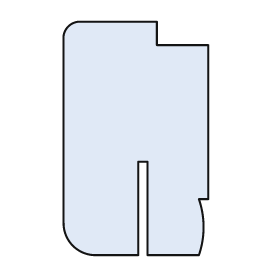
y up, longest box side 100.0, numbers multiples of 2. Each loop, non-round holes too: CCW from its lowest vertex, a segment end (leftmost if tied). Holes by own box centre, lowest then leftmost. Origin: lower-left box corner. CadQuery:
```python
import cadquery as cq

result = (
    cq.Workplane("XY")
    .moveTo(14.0, 0.0)
    .lineTo(32.0, 0.0)
    .lineTo(32.0, 40.0)
    .lineTo(36.0, 40.0)
    .lineTo(36.0, 0.0)
    .lineTo(58.0, 0.0)
    .threePointArc((60.0, 12.0), (58.0, 24.0))
    .lineTo(62.0, 24.0)
    .lineTo(62.0, 90.0)
    .lineTo(40.0, 90.0)
    .lineTo(40.0, 100.0)
    .lineTo(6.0, 100.0)
    .threePointArc((2.0, 98.0), (0.0, 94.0))
    .lineTo(0.0, 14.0)
    .threePointArc((4.0, 4.0), (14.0, 0.0))
    .close()
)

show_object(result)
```